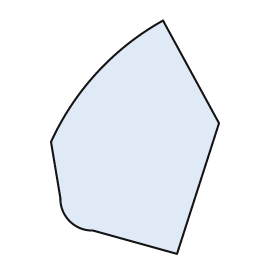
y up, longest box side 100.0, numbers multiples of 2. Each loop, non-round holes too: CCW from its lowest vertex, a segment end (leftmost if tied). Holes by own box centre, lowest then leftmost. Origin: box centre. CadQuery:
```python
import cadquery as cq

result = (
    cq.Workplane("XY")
    .moveTo(18.0, -50.0)
    .lineTo(36.0, 6.0)
    .lineTo(12.0, 50.0)
    .threePointArc((-16.0, 28.0), (-36.0, -2.0))
    .lineTo(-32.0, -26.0)
    .threePointArc((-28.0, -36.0), (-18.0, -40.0))
    .close()
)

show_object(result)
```